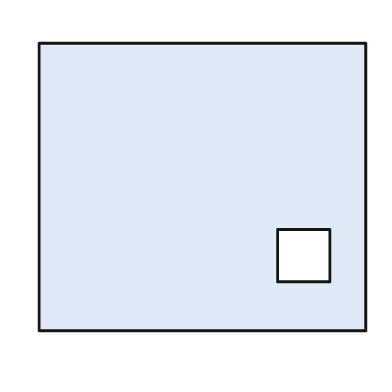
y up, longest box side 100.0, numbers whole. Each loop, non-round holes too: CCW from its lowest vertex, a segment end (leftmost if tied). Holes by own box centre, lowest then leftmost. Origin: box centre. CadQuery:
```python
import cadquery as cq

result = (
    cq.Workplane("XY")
    .moveTo(-50.0, -44.0)
    .lineTo(50.0, -44.0)
    .lineTo(50.0, 44.0)
    .lineTo(-50.0, 44.0)
    .close()
    .moveTo(23.0, -29.0)
    .lineTo(39.0, -29.0)
    .lineTo(39.0, -13.0)
    .lineTo(23.0, -13.0)
    .close()
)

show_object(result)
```